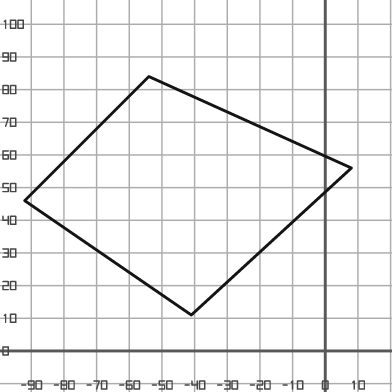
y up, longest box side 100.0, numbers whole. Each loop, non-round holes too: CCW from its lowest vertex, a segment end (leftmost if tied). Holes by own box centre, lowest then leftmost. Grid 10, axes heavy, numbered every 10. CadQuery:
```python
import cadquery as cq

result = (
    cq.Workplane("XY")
    .moveTo(-41.0, 11.0)
    .lineTo(8.0, 56.0)
    .lineTo(-54.0, 84.0)
    .lineTo(-92.0, 46.0)
    .close()
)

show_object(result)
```